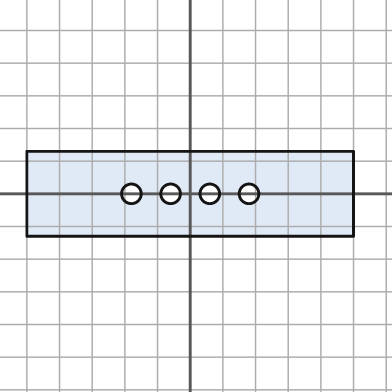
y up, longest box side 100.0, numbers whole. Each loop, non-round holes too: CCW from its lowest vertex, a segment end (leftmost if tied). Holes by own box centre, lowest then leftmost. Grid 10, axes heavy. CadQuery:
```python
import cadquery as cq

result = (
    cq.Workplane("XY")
    .moveTo(-50.0, -13.0)
    .lineTo(50.0, -13.0)
    .lineTo(50.0, 13.0)
    .lineTo(-50.0, 13.0)
    .close()
    .moveTo(-18.0, 0.0)
    .circle(3.0)
    .moveTo(-6.0, 0.0)
    .circle(3.0)
    .moveTo(6.0, 0.0)
    .circle(3.0)
    .moveTo(18.0, 0.0)
    .circle(3.0)
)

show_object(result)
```